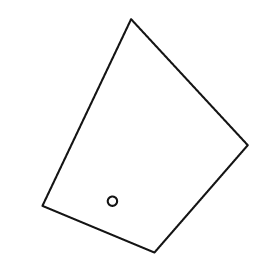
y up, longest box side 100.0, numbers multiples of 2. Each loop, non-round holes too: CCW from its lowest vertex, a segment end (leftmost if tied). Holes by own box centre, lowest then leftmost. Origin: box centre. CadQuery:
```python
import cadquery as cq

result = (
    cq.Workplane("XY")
    .moveTo(4.0, -50.0)
    .lineTo(44.0, -4.0)
    .lineTo(-6.0, 50.0)
    .lineTo(-44.0, -30.0)
    .close()
    .moveTo(-14.0, -28.0)
    .circle(2.0)
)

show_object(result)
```